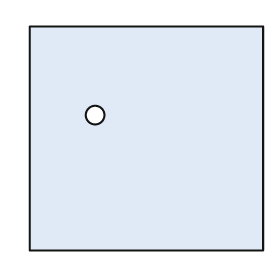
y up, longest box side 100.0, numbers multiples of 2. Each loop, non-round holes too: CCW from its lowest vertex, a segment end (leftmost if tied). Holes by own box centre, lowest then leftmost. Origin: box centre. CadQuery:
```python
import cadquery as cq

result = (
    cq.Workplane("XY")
    .moveTo(-50.0, -48.0)
    .lineTo(50.0, -48.0)
    .lineTo(50.0, 48.0)
    .lineTo(-50.0, 48.0)
    .close()
    .moveTo(-22.0, 10.0)
    .circle(4.0)
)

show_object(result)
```